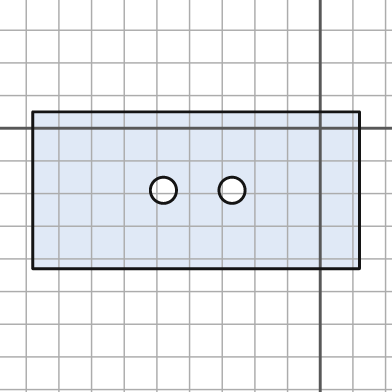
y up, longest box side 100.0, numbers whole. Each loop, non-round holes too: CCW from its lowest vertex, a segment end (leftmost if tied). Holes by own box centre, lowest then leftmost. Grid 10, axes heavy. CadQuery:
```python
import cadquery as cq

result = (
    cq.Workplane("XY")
    .moveTo(-88.0, -43.0)
    .lineTo(12.0, -43.0)
    .lineTo(12.0, 5.0)
    .lineTo(-88.0, 5.0)
    .close()
    .moveTo(-48.0, -19.0)
    .circle(4.0)
    .moveTo(-27.0, -19.0)
    .circle(4.0)
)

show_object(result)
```